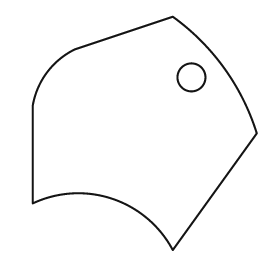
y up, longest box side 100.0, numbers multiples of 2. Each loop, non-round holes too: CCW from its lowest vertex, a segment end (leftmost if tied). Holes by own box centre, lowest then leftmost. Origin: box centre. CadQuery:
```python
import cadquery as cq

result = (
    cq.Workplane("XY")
    .moveTo(12.0, -50.0)
    .lineTo(48.0, 0.0)
    .threePointArc((34.0, 28.0), (12.0, 50.0))
    .lineTo(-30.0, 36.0)
    .threePointArc((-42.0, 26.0), (-48.0, 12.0))
    .lineTo(-48.0, -30.0)
    .threePointArc((-14.0, -28.0), (12.0, -50.0))
    .close()
    .moveTo(20.0, 24.0)
    .circle(6.0)
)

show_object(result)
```